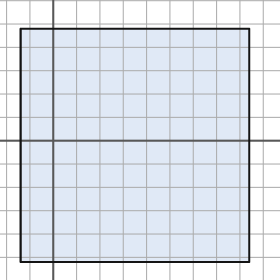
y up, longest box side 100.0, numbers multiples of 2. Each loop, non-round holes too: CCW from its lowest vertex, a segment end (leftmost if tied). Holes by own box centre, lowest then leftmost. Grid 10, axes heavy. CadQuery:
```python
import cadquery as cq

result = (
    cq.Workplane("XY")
    .moveTo(-14.0, -52.0)
    .lineTo(84.0, -52.0)
    .lineTo(84.0, 48.0)
    .lineTo(-14.0, 48.0)
    .close()
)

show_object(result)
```